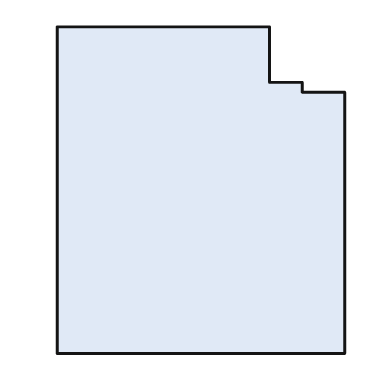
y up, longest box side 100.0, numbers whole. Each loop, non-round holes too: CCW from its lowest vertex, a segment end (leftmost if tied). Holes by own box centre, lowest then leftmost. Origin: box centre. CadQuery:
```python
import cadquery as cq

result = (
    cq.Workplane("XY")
    .moveTo(-44.0, -50.0)
    .lineTo(44.0, -50.0)
    .lineTo(44.0, 30.0)
    .lineTo(31.0, 30.0)
    .lineTo(31.0, 33.0)
    .lineTo(21.0, 33.0)
    .lineTo(21.0, 50.0)
    .lineTo(-44.0, 50.0)
    .close()
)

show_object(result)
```